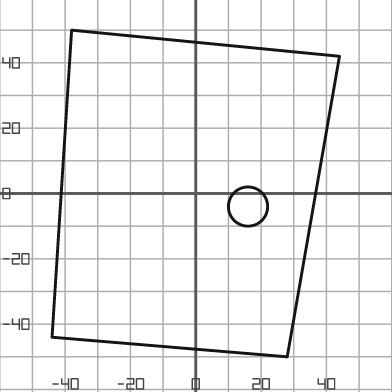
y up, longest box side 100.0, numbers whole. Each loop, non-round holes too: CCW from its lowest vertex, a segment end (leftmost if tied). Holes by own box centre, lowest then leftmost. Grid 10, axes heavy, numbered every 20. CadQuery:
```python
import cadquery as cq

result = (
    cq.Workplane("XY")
    .moveTo(28.0, -50.0)
    .lineTo(44.0, 42.0)
    .lineTo(-38.0, 50.0)
    .lineTo(-44.0, -44.0)
    .close()
    .moveTo(16.0, -4.0)
    .circle(6.0)
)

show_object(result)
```